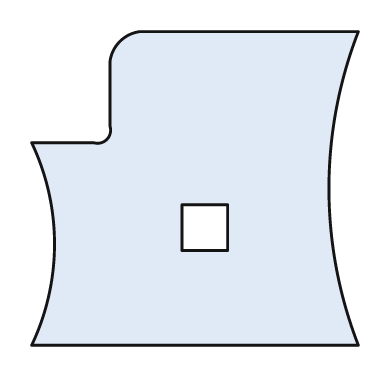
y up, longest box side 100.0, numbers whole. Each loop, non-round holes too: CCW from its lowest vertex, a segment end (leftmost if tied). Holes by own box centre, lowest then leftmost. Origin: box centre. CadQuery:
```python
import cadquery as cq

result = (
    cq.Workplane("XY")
    .moveTo(-50.0, -48.0)
    .lineTo(50.0, -48.0)
    .threePointArc((41.0, 0.0), (50.0, 48.0))
    .lineTo(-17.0, 48.0)
    .threePointArc((-23.0, 45.0), (-26.0, 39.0))
    .lineTo(-26.0, 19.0)
    .threePointArc((-27.0, 15.0), (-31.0, 14.0))
    .lineTo(-50.0, 14.0)
    .threePointArc((-43.0, -17.0), (-50.0, -48.0))
    .close()
    .moveTo(-4.0, -19.0)
    .lineTo(10.0, -19.0)
    .lineTo(10.0, -5.0)
    .lineTo(-4.0, -5.0)
    .close()
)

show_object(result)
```